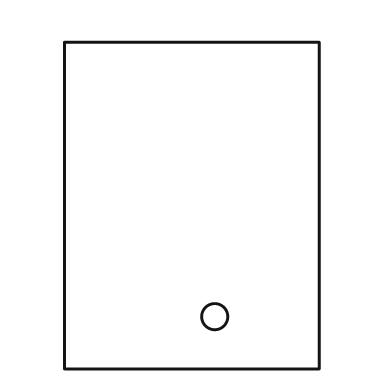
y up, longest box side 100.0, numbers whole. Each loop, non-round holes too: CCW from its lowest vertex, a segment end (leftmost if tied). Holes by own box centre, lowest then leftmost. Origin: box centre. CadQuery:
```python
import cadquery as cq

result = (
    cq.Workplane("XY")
    .moveTo(-39.0, -50.0)
    .lineTo(39.0, -50.0)
    .lineTo(39.0, 50.0)
    .lineTo(-39.0, 50.0)
    .close()
    .moveTo(7.0, -34.0)
    .circle(4.0)
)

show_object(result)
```